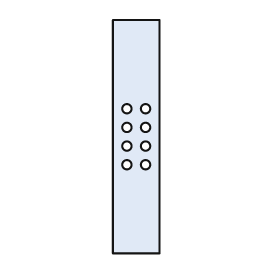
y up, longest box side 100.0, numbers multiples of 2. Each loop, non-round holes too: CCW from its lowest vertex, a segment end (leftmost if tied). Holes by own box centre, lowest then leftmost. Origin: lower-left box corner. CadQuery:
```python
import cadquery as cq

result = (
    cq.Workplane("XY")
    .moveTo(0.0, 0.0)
    .lineTo(20.0, 0.0)
    .lineTo(20.0, 100.0)
    .lineTo(0.0, 100.0)
    .close()
    .moveTo(6.0, 38.0)
    .circle(2.0)
    .moveTo(14.0, 38.0)
    .circle(2.0)
    .moveTo(6.0, 46.0)
    .circle(2.0)
    .moveTo(14.0, 46.0)
    .circle(2.0)
    .moveTo(6.0, 54.0)
    .circle(2.0)
    .moveTo(14.0, 54.0)
    .circle(2.0)
    .moveTo(6.0, 62.0)
    .circle(2.0)
    .moveTo(14.0, 62.0)
    .circle(2.0)
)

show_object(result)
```